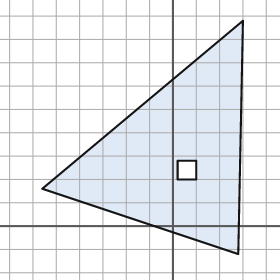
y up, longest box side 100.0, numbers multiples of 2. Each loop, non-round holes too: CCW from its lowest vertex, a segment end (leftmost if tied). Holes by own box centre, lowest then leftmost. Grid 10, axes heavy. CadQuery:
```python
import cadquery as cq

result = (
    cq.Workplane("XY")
    .moveTo(28.0, -12.0)
    .lineTo(30.0, 88.0)
    .lineTo(-56.0, 16.0)
    .close()
    .moveTo(2.0, 20.0)
    .lineTo(10.0, 20.0)
    .lineTo(10.0, 28.0)
    .lineTo(2.0, 28.0)
    .close()
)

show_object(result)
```